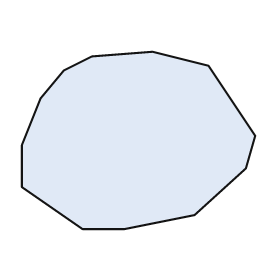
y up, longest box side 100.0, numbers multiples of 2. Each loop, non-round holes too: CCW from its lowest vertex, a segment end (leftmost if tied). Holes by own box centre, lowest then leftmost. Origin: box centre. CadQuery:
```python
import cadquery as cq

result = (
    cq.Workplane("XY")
    .moveTo(-24.0, -38.0)
    .lineTo(-6.0, -38.0)
    .lineTo(24.0, -32.0)
    .lineTo(46.0, -12.0)
    .lineTo(50.0, 2.0)
    .lineTo(30.0, 32.0)
    .lineTo(6.0, 38.0)
    .lineTo(-20.0, 36.0)
    .lineTo(-32.0, 30.0)
    .lineTo(-42.0, 18.0)
    .lineTo(-50.0, -2.0)
    .lineTo(-50.0, -20.0)
    .close()
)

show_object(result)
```